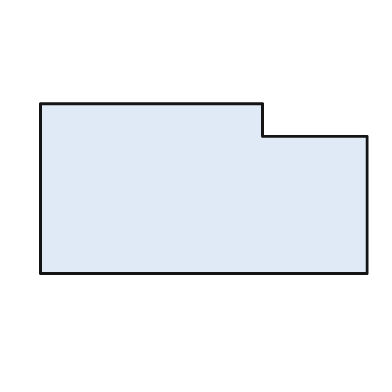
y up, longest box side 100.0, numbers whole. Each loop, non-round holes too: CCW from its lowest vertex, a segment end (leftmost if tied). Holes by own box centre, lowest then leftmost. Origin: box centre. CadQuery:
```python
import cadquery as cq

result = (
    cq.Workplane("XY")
    .moveTo(-50.0, -26.0)
    .lineTo(50.0, -26.0)
    .lineTo(50.0, 16.0)
    .lineTo(18.0, 16.0)
    .lineTo(18.0, 26.0)
    .lineTo(-50.0, 26.0)
    .close()
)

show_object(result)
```